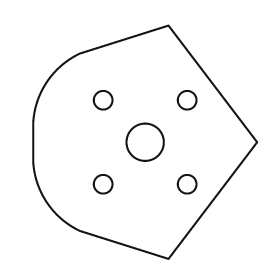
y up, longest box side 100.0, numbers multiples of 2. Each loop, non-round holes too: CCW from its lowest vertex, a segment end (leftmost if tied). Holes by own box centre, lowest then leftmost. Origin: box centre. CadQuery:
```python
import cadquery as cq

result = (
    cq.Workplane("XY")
    .moveTo(10.0, -50.0)
    .lineTo(48.0, 0.0)
    .lineTo(10.0, 50.0)
    .lineTo(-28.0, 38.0)
    .threePointArc((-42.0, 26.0), (-48.0, 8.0))
    .lineTo(-48.0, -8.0)
    .threePointArc((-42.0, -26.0), (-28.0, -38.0))
    .close()
    .moveTo(-18.0, -18.0)
    .circle(4.0)
    .moveTo(18.0, -18.0)
    .circle(4.0)
    .moveTo(0.0, 0.0)
    .circle(8.0)
    .moveTo(-18.0, 18.0)
    .circle(4.0)
    .moveTo(18.0, 18.0)
    .circle(4.0)
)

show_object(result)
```